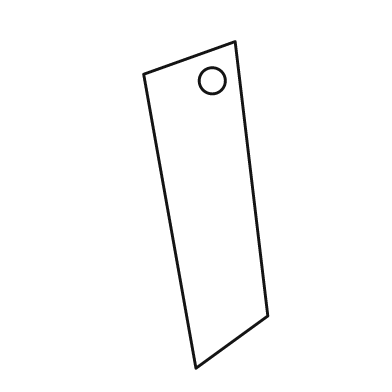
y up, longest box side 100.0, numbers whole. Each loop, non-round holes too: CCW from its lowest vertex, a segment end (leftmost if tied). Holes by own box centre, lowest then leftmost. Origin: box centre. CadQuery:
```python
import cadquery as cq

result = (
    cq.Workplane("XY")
    .moveTo(-3.0, -50.0)
    .lineTo(19.0, -34.0)
    .lineTo(9.0, 50.0)
    .lineTo(-19.0, 40.0)
    .close()
    .moveTo(2.0, 38.0)
    .circle(4.0)
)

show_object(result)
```